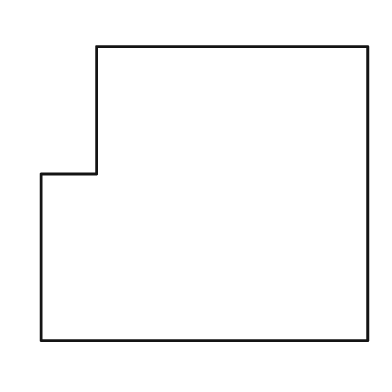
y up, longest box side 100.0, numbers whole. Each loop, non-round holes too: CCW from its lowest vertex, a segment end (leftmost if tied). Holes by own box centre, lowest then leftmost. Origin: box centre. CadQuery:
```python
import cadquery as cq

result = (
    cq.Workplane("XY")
    .moveTo(-50.0, -45.0)
    .lineTo(50.0, -45.0)
    .lineTo(50.0, 45.0)
    .lineTo(-33.0, 45.0)
    .lineTo(-33.0, 6.0)
    .lineTo(-50.0, 6.0)
    .close()
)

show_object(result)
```